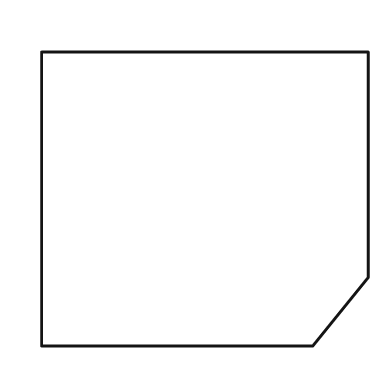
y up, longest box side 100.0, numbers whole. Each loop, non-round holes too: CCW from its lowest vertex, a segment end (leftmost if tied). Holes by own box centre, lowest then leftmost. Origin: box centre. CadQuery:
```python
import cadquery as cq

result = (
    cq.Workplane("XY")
    .moveTo(-50.0, -45.0)
    .lineTo(33.0, -45.0)
    .lineTo(50.0, -24.0)
    .lineTo(50.0, 45.0)
    .lineTo(-50.0, 45.0)
    .close()
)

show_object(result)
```